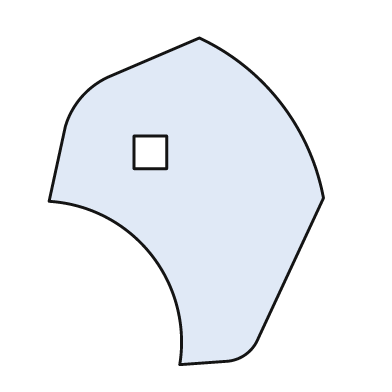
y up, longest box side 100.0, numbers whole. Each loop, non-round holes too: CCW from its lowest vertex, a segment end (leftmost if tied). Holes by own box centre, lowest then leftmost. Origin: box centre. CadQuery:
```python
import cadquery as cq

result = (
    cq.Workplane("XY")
    .moveTo(-2.0, -50.0)
    .lineTo(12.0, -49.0)
    .threePointArc((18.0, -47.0), (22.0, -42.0))
    .lineTo(42.0, 1.0)
    .threePointArc((29.0, 30.0), (4.0, 50.0))
    .lineTo(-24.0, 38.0)
    .threePointArc((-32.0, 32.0), (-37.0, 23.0))
    .lineTo(-42.0, 0.0)
    .threePointArc((-11.0, -16.0), (-2.0, -50.0))
    .close()
    .moveTo(-16.0, 10.0)
    .lineTo(-6.0, 10.0)
    .lineTo(-6.0, 20.0)
    .lineTo(-16.0, 20.0)
    .close()
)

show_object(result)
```